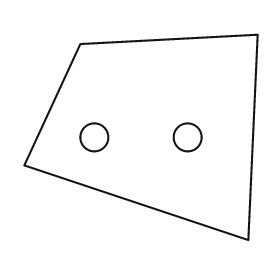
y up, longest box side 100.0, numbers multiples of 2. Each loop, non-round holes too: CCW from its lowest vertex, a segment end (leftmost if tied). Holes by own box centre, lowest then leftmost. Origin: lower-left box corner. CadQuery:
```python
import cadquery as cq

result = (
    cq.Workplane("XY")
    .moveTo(96.0, 0.0)
    .lineTo(100.0, 88.0)
    .lineTo(24.0, 84.0)
    .lineTo(0.0, 32.0)
    .close()
    .moveTo(30.0, 44.0)
    .circle(6.0)
    .moveTo(70.0, 44.0)
    .circle(6.0)
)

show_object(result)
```